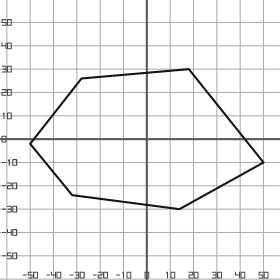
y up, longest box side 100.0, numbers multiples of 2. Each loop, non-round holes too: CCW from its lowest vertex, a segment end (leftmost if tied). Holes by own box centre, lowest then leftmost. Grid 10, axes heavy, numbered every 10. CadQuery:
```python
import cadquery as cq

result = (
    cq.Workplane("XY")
    .moveTo(14.0, -30.0)
    .lineTo(50.0, -10.0)
    .lineTo(18.0, 30.0)
    .lineTo(-28.0, 26.0)
    .lineTo(-50.0, -2.0)
    .lineTo(-32.0, -24.0)
    .close()
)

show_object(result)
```